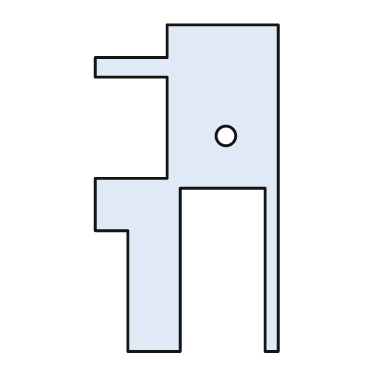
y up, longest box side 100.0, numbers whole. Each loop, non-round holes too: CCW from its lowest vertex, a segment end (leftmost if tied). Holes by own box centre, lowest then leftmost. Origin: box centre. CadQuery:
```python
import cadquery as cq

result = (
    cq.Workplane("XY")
    .moveTo(-18.0, -50.0)
    .lineTo(-2.0, -50.0)
    .lineTo(-2.0, 0.0)
    .lineTo(24.0, 0.0)
    .lineTo(24.0, -50.0)
    .lineTo(28.0, -50.0)
    .lineTo(28.0, 50.0)
    .lineTo(-6.0, 50.0)
    .lineTo(-6.0, 40.0)
    .lineTo(-28.0, 40.0)
    .lineTo(-28.0, 34.0)
    .lineTo(-6.0, 34.0)
    .lineTo(-6.0, 3.0)
    .lineTo(-28.0, 3.0)
    .lineTo(-28.0, -13.0)
    .lineTo(-18.0, -13.0)
    .close()
    .moveTo(12.0, 16.0)
    .circle(3.0)
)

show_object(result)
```